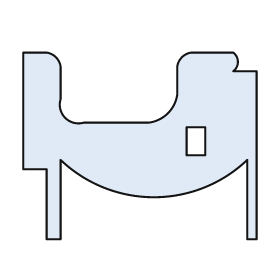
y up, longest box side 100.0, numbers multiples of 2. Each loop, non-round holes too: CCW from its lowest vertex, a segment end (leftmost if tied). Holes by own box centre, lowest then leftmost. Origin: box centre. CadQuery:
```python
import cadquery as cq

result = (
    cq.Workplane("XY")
    .moveTo(-40.0, -40.0)
    .lineTo(-34.0, -40.0)
    .lineTo(-34.0, -6.0)
    .threePointArc((6.0, -22.0), (46.0, -6.0))
    .lineTo(46.0, -40.0)
    .lineTo(50.0, -40.0)
    .lineTo(50.0, 32.0)
    .lineTo(40.0, 32.0)
    .threePointArc((42.0, 36.0), (40.0, 40.0))
    .lineTo(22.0, 40.0)
    .threePointArc((18.0, 38.0), (16.0, 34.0))
    .lineTo(16.0, 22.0)
    .threePointArc((12.0, 14.0), (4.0, 10.0))
    .lineTo(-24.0, 10.0)
    .threePointArc((-32.0, 12.0), (-34.0, 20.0))
    .lineTo(-34.0, 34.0)
    .threePointArc((-36.0, 38.0), (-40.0, 40.0))
    .lineTo(-50.0, 40.0)
    .lineTo(-50.0, -10.0)
    .lineTo(-40.0, -10.0)
    .close()
    .moveTo(20.0, -4.0)
    .lineTo(28.0, -4.0)
    .lineTo(28.0, 8.0)
    .lineTo(20.0, 8.0)
    .close()
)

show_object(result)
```